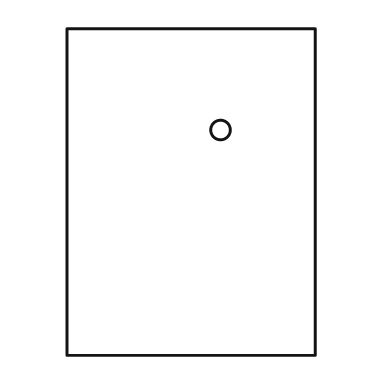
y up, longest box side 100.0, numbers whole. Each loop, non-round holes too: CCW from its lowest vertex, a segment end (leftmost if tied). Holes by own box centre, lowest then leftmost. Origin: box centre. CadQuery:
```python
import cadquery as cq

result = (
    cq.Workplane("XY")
    .moveTo(-38.0, -50.0)
    .lineTo(38.0, -50.0)
    .lineTo(38.0, 50.0)
    .lineTo(-38.0, 50.0)
    .close()
    .moveTo(9.0, 19.0)
    .circle(3.0)
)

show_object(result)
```